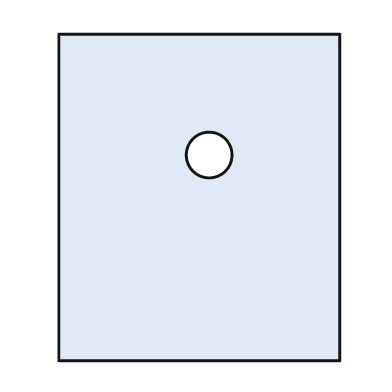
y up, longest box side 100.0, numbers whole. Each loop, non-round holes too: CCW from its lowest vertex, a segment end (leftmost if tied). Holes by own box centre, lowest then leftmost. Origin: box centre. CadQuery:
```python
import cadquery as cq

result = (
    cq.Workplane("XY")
    .moveTo(-43.0, -50.0)
    .lineTo(43.0, -50.0)
    .lineTo(43.0, 50.0)
    .lineTo(-43.0, 50.0)
    .close()
    .moveTo(3.0, 13.0)
    .circle(7.0)
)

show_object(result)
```